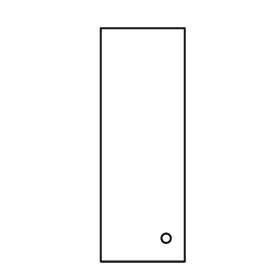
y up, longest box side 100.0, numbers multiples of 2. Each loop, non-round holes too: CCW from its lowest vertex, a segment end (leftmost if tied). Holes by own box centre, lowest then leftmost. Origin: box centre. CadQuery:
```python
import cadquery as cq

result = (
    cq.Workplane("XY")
    .moveTo(-18.0, -50.0)
    .lineTo(18.0, -50.0)
    .lineTo(18.0, 50.0)
    .lineTo(-18.0, 50.0)
    .close()
    .moveTo(10.0, -40.0)
    .circle(2.0)
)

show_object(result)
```